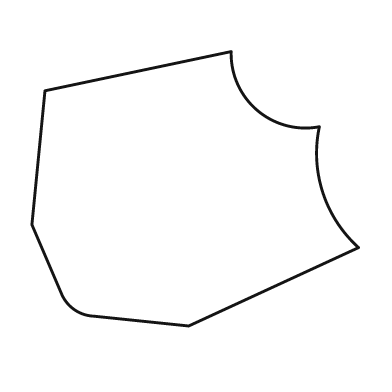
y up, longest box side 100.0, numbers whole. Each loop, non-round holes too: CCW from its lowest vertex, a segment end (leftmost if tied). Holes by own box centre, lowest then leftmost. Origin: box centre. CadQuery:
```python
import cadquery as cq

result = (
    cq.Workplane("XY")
    .moveTo(-2.0, -42.0)
    .lineTo(50.0, -18.0)
    .threePointArc((39.0, -1.0), (38.0, 19.0))
    .threePointArc((19.0, 24.0), (11.0, 42.0))
    .lineTo(-46.0, 30.0)
    .lineTo(-50.0, -11.0)
    .lineTo(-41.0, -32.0)
    .threePointArc((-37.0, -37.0), (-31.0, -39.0))
    .close()
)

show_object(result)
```